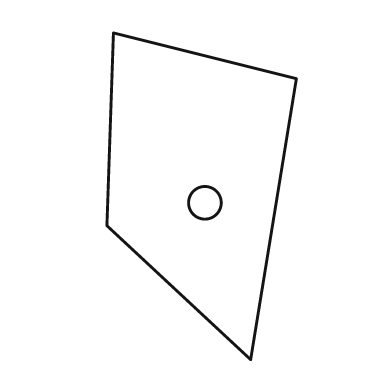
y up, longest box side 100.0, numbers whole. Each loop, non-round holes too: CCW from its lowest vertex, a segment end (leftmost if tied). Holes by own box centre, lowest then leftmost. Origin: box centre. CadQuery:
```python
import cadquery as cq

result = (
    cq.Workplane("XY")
    .moveTo(15.0, -50.0)
    .lineTo(29.0, 36.0)
    .lineTo(-27.0, 50.0)
    .lineTo(-29.0, -9.0)
    .close()
    .moveTo(1.0, -2.0)
    .circle(5.0)
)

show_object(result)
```